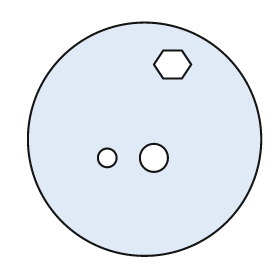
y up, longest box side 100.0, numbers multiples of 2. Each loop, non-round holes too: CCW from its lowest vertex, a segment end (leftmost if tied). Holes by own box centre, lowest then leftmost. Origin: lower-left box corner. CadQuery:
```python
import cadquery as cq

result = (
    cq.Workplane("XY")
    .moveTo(50.0, 50.0)
    .circle(50.0)
    .moveTo(34.0, 42.0)
    .circle(4.0)
    .moveTo(54.0, 42.0)
    .circle(6.0)
    .moveTo(58.0, 76.0)
    .lineTo(66.0, 76.0)
    .lineTo(70.0, 82.0)
    .lineTo(66.0, 88.0)
    .lineTo(58.0, 88.0)
    .lineTo(54.0, 82.0)
    .close()
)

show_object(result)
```